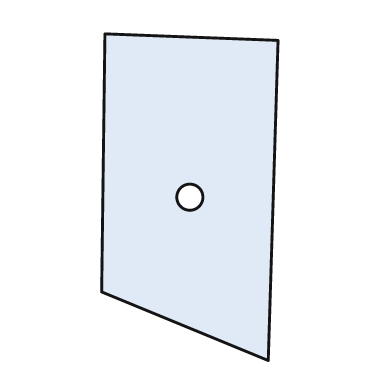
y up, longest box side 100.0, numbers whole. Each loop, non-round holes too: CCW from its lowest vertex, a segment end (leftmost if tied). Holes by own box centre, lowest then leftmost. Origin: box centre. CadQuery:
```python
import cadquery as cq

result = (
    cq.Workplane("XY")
    .moveTo(24.0, -50.0)
    .lineTo(27.0, 48.0)
    .lineTo(-26.0, 50.0)
    .lineTo(-27.0, -29.0)
    .close()
    .moveTo(0.0, 0.0)
    .circle(4.0)
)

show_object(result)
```